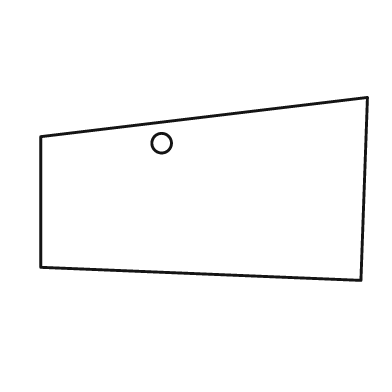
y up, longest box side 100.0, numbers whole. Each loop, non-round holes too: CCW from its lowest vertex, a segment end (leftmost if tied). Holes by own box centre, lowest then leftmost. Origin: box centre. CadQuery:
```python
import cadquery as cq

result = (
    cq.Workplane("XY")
    .moveTo(48.0, -28.0)
    .lineTo(50.0, 28.0)
    .lineTo(-50.0, 16.0)
    .lineTo(-50.0, -24.0)
    .close()
    .moveTo(-13.0, 14.0)
    .circle(3.0)
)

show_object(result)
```